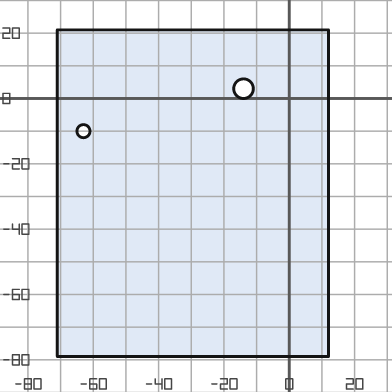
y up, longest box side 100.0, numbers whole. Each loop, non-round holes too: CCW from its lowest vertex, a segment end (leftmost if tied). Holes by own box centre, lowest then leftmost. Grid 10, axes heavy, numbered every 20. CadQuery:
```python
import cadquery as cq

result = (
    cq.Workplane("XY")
    .moveTo(-71.0, -79.0)
    .lineTo(12.0, -79.0)
    .lineTo(12.0, 21.0)
    .lineTo(-71.0, 21.0)
    .close()
    .moveTo(-63.0, -10.0)
    .circle(2.0)
    .moveTo(-14.0, 3.0)
    .circle(3.0)
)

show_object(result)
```